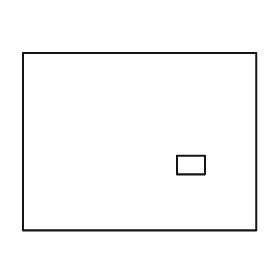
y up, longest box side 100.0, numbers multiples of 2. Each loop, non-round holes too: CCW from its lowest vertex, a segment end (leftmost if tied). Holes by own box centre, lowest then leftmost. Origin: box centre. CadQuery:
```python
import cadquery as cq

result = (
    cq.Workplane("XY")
    .moveTo(-50.0, -38.0)
    .lineTo(50.0, -38.0)
    .lineTo(50.0, 38.0)
    .lineTo(-50.0, 38.0)
    .close()
    .moveTo(16.0, -14.0)
    .lineTo(28.0, -14.0)
    .lineTo(28.0, -6.0)
    .lineTo(16.0, -6.0)
    .close()
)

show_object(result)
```